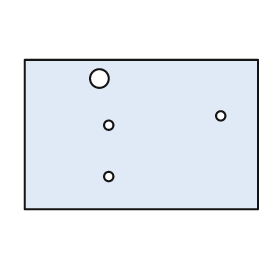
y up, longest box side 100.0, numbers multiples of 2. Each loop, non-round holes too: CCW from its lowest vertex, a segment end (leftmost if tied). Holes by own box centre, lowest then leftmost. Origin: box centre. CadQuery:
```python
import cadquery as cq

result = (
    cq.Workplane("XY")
    .moveTo(-50.0, -32.0)
    .lineTo(50.0, -32.0)
    .lineTo(50.0, 32.0)
    .lineTo(-50.0, 32.0)
    .close()
    .moveTo(-14.0, -18.0)
    .circle(2.0)
    .moveTo(-14.0, 4.0)
    .circle(2.0)
    .moveTo(34.0, 8.0)
    .circle(2.0)
    .moveTo(-18.0, 24.0)
    .circle(4.0)
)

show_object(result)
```